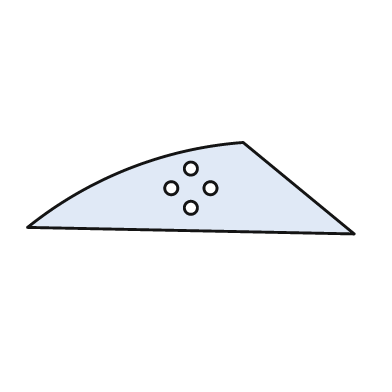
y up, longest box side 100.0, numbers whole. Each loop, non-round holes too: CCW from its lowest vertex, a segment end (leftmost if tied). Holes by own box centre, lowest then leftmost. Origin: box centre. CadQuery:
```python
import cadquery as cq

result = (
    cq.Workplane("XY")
    .moveTo(50.0, -14.0)
    .lineTo(16.0, 14.0)
    .threePointArc((-19.0, 6.0), (-50.0, -12.0))
    .close()
    .moveTo(0.0, -6.0)
    .circle(2.0)
    .moveTo(-6.0, 0.0)
    .circle(2.0)
    .moveTo(6.0, 0.0)
    .circle(2.0)
    .moveTo(0.0, 6.0)
    .circle(2.0)
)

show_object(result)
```